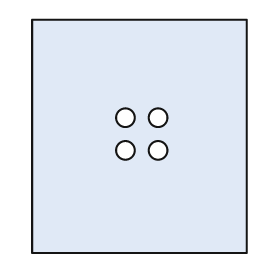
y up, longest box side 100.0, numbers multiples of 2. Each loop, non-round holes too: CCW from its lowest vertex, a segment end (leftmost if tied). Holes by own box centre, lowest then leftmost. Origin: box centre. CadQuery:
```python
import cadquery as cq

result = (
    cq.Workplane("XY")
    .moveTo(-46.0, -50.0)
    .lineTo(46.0, -50.0)
    .lineTo(46.0, 50.0)
    .lineTo(-46.0, 50.0)
    .close()
    .moveTo(-6.0, -6.0)
    .circle(4.0)
    .moveTo(8.0, -6.0)
    .circle(4.0)
    .moveTo(-6.0, 8.0)
    .circle(4.0)
    .moveTo(8.0, 8.0)
    .circle(4.0)
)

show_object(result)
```